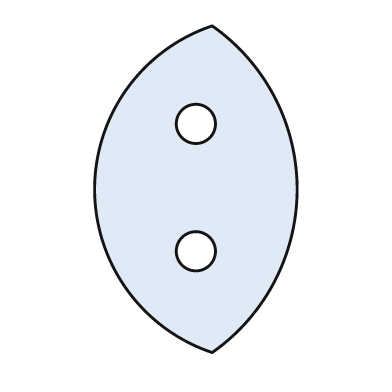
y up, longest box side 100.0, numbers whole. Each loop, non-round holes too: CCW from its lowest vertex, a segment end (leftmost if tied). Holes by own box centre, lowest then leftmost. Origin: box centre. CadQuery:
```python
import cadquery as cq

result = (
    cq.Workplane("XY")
    .moveTo(5.0, -50.0)
    .threePointArc((31.0, 0.0), (5.0, 50.0))
    .threePointArc((-31.0, 0.0), (5.0, -50.0))
    .close()
    .moveTo(0.0, -19.0)
    .circle(6.0)
    .moveTo(0.0, 20.0)
    .circle(6.0)
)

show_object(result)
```